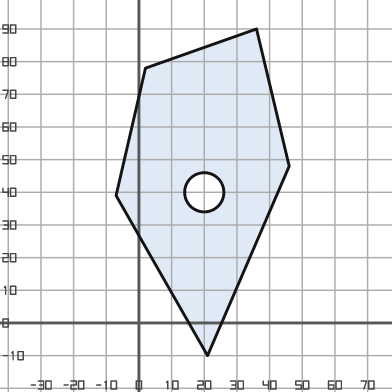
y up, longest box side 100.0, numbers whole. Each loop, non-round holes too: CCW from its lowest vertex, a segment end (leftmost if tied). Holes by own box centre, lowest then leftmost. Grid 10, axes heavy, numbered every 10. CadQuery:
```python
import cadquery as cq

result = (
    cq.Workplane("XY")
    .moveTo(21.0, -10.0)
    .lineTo(46.0, 48.0)
    .lineTo(36.0, 90.0)
    .lineTo(2.0, 78.0)
    .lineTo(-7.0, 39.0)
    .close()
    .moveTo(20.0, 40.0)
    .circle(6.0)
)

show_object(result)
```